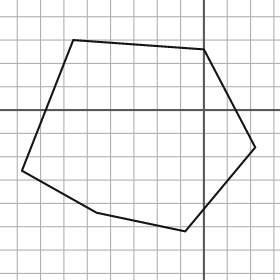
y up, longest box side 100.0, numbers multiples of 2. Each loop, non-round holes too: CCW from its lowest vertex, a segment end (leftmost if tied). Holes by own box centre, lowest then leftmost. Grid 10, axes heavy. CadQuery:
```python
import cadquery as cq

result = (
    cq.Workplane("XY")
    .moveTo(-8.0, -52.0)
    .lineTo(22.0, -16.0)
    .lineTo(0.0, 26.0)
    .lineTo(-56.0, 30.0)
    .lineTo(-78.0, -26.0)
    .lineTo(-46.0, -44.0)
    .close()
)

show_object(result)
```